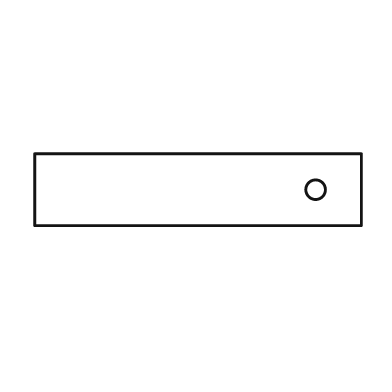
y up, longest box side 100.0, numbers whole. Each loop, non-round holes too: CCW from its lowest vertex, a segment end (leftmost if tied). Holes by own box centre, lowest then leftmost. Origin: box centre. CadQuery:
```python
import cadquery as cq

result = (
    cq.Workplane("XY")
    .moveTo(-50.0, -11.0)
    .lineTo(50.0, -11.0)
    .lineTo(50.0, 11.0)
    .lineTo(-50.0, 11.0)
    .close()
    .moveTo(36.0, 0.0)
    .circle(3.0)
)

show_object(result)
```